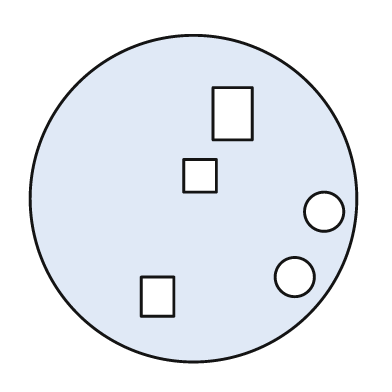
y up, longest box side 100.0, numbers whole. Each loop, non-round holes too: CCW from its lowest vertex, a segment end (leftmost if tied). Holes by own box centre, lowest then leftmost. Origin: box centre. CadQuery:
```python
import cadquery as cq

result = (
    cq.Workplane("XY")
    .moveTo(0.0, 0.0)
    .circle(50.0)
    .moveTo(-16.0, -36.0)
    .lineTo(-6.0, -36.0)
    .lineTo(-6.0, -24.0)
    .lineTo(-16.0, -24.0)
    .close()
    .moveTo(31.0, -24.0)
    .circle(6.0)
    .moveTo(40.0, -4.0)
    .circle(6.0)
    .moveTo(-3.0, 2.0)
    .lineTo(7.0, 2.0)
    .lineTo(7.0, 12.0)
    .lineTo(-3.0, 12.0)
    .close()
    .moveTo(6.0, 18.0)
    .lineTo(18.0, 18.0)
    .lineTo(18.0, 34.0)
    .lineTo(6.0, 34.0)
    .close()
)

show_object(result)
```